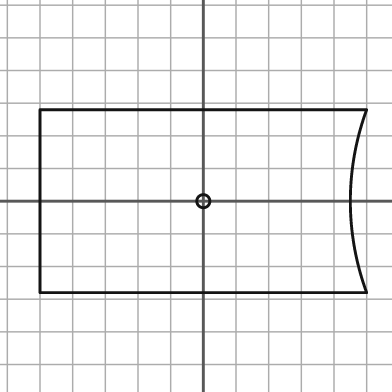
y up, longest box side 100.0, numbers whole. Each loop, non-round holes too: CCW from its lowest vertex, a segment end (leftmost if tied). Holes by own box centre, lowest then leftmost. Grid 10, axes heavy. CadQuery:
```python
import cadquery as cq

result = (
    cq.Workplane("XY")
    .moveTo(-50.0, -28.0)
    .lineTo(50.0, -28.0)
    .threePointArc((45.0, 0.0), (50.0, 28.0))
    .lineTo(-50.0, 28.0)
    .close()
    .moveTo(0.0, 0.0)
    .circle(2.0)
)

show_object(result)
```